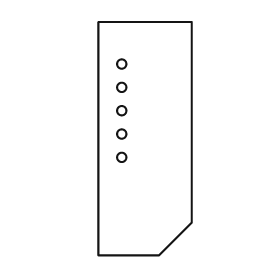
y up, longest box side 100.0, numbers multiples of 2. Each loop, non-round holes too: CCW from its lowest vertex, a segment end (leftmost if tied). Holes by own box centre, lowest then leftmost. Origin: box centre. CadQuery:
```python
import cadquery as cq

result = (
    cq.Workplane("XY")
    .moveTo(-20.0, -50.0)
    .lineTo(6.0, -50.0)
    .lineTo(20.0, -36.0)
    .lineTo(20.0, 50.0)
    .lineTo(-20.0, 50.0)
    .close()
    .moveTo(-10.0, -8.0)
    .circle(2.0)
    .moveTo(-10.0, 2.0)
    .circle(2.0)
    .moveTo(-10.0, 12.0)
    .circle(2.0)
    .moveTo(-10.0, 22.0)
    .circle(2.0)
    .moveTo(-10.0, 32.0)
    .circle(2.0)
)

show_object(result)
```